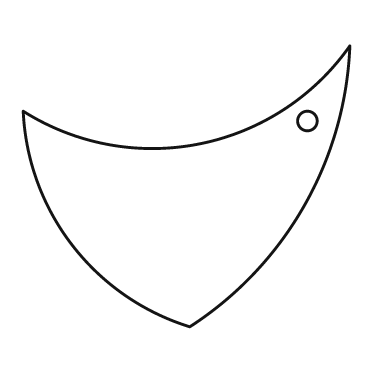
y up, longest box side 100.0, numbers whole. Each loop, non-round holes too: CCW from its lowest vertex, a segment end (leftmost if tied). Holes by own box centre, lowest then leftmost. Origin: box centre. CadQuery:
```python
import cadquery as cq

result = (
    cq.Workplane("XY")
    .moveTo(1.0, -43.0)
    .threePointArc((36.0, -6.0), (50.0, 43.0))
    .threePointArc((4.0, 13.0), (-50.0, 23.0))
    .threePointArc((-35.0, -18.0), (1.0, -43.0))
    .close()
    .moveTo(37.0, 20.0)
    .circle(3.0)
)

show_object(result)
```